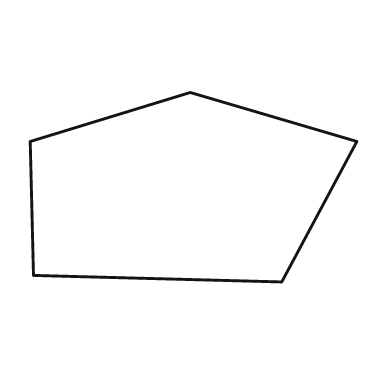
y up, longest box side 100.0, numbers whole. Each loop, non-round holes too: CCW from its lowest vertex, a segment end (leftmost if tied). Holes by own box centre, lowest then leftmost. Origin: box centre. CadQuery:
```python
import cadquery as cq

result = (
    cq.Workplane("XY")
    .moveTo(27.0, -29.0)
    .lineTo(50.0, 14.0)
    .lineTo(-1.0, 29.0)
    .lineTo(-50.0, 14.0)
    .lineTo(-49.0, -27.0)
    .close()
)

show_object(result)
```